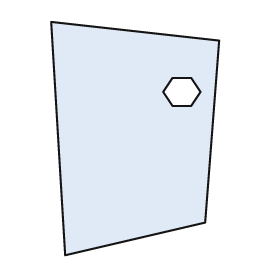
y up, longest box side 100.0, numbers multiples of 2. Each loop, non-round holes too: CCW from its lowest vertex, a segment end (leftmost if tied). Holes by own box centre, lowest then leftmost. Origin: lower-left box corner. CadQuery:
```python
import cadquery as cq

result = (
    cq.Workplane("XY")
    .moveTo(6.0, 0.0)
    .lineTo(66.0, 14.0)
    .lineTo(72.0, 92.0)
    .lineTo(0.0, 100.0)
    .close()
    .moveTo(52.0, 64.0)
    .lineTo(60.0, 64.0)
    .lineTo(64.0, 70.0)
    .lineTo(60.0, 76.0)
    .lineTo(52.0, 76.0)
    .lineTo(48.0, 70.0)
    .close()
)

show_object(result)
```